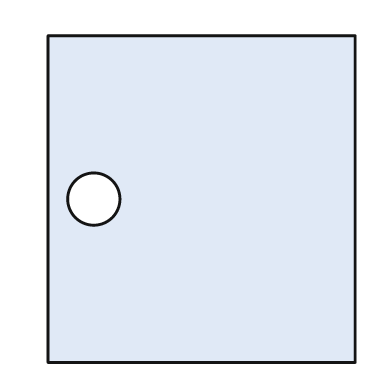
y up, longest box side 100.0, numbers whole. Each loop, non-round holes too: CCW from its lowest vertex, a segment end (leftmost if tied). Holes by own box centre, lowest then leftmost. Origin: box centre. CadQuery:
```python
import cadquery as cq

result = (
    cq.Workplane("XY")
    .moveTo(-47.0, -50.0)
    .lineTo(47.0, -50.0)
    .lineTo(47.0, 50.0)
    .lineTo(-47.0, 50.0)
    .close()
    .moveTo(-33.0, 0.0)
    .circle(8.0)
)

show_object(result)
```